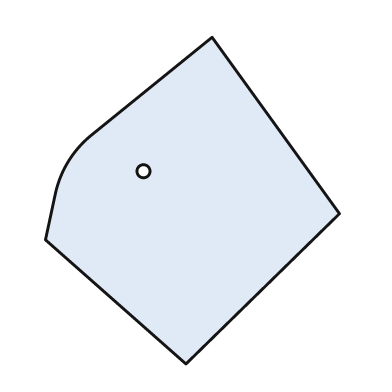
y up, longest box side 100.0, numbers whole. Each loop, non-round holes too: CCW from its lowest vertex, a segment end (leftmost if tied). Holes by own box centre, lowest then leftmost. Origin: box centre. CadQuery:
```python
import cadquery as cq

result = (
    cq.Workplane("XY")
    .moveTo(-2.0, -50.0)
    .lineTo(45.0, -4.0)
    .lineTo(6.0, 50.0)
    .lineTo(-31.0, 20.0)
    .threePointArc((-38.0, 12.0), (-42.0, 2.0))
    .lineTo(-45.0, -12.0)
    .close()
    .moveTo(-15.0, 9.0)
    .circle(2.0)
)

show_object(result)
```